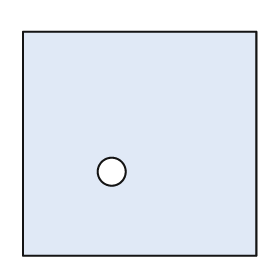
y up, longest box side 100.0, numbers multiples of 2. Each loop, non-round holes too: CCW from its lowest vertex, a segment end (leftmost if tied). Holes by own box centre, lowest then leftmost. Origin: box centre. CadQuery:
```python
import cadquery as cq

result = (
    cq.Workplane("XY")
    .moveTo(-50.0, -48.0)
    .lineTo(50.0, -48.0)
    .lineTo(50.0, 48.0)
    .lineTo(-50.0, 48.0)
    .close()
    .moveTo(-12.0, -12.0)
    .circle(6.0)
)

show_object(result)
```